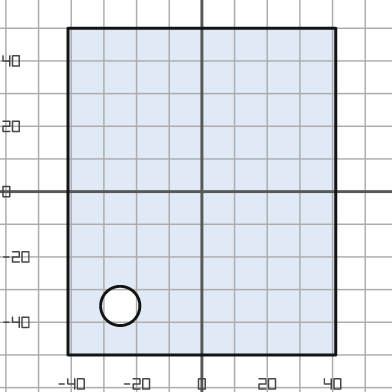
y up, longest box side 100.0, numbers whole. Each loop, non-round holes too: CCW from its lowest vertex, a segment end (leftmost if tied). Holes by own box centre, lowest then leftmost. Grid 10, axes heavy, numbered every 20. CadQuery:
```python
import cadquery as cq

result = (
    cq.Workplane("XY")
    .moveTo(-41.0, -50.0)
    .lineTo(41.0, -50.0)
    .lineTo(41.0, 50.0)
    .lineTo(-41.0, 50.0)
    .close()
    .moveTo(-25.0, -35.0)
    .circle(6.0)
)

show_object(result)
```